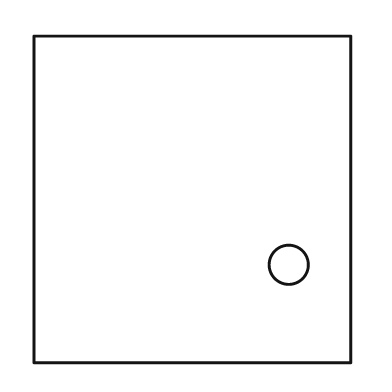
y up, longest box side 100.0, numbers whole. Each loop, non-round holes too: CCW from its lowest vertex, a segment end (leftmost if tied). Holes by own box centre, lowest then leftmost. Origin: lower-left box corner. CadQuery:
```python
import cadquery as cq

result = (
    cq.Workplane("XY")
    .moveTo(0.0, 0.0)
    .lineTo(97.0, 0.0)
    .lineTo(97.0, 100.0)
    .lineTo(0.0, 100.0)
    .close()
    .moveTo(78.0, 30.0)
    .circle(6.0)
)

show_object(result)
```